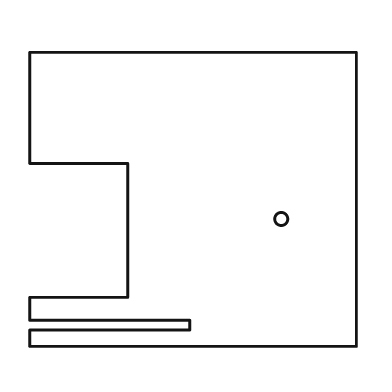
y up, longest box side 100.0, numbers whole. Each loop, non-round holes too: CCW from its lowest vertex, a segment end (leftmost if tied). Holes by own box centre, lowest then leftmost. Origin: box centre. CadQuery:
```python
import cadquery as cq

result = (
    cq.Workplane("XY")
    .moveTo(-50.0, -45.0)
    .lineTo(50.0, -45.0)
    .lineTo(50.0, 45.0)
    .lineTo(-50.0, 45.0)
    .lineTo(-50.0, 11.0)
    .lineTo(-20.0, 11.0)
    .lineTo(-20.0, -30.0)
    .lineTo(-50.0, -30.0)
    .lineTo(-50.0, -37.0)
    .lineTo(-1.0, -37.0)
    .lineTo(-1.0, -40.0)
    .lineTo(-50.0, -40.0)
    .close()
    .moveTo(27.0, -6.0)
    .circle(2.0)
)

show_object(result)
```